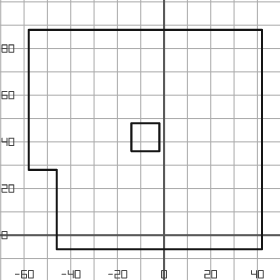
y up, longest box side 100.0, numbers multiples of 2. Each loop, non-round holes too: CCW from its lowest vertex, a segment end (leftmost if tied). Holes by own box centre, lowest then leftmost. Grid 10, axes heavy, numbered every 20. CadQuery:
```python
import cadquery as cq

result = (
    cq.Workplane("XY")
    .moveTo(-46.0, -6.0)
    .lineTo(42.0, -6.0)
    .lineTo(42.0, 88.0)
    .lineTo(-58.0, 88.0)
    .lineTo(-58.0, 28.0)
    .lineTo(-46.0, 28.0)
    .close()
    .moveTo(-14.0, 36.0)
    .lineTo(-2.0, 36.0)
    .lineTo(-2.0, 48.0)
    .lineTo(-14.0, 48.0)
    .close()
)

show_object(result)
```